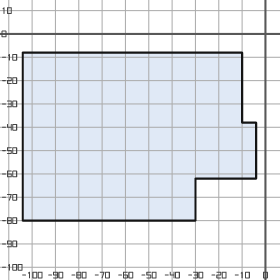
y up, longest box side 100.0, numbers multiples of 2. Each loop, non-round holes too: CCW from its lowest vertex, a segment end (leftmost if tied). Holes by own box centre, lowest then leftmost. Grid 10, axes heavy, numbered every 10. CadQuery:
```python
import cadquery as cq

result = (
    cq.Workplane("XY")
    .moveTo(-104.0, -80.0)
    .lineTo(-30.0, -80.0)
    .lineTo(-30.0, -62.0)
    .lineTo(-4.0, -62.0)
    .lineTo(-4.0, -38.0)
    .lineTo(-10.0, -38.0)
    .lineTo(-10.0, -8.0)
    .lineTo(-104.0, -8.0)
    .close()
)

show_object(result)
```